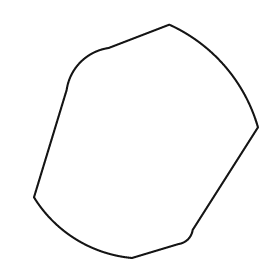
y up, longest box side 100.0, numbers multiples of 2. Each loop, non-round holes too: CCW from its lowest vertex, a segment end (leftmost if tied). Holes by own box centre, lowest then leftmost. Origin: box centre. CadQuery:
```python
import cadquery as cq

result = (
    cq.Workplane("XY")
    .moveTo(-6.0, -50.0)
    .lineTo(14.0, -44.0)
    .threePointArc((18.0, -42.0), (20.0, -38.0))
    .lineTo(48.0, 6.0)
    .threePointArc((34.0, 32.0), (10.0, 50.0))
    .lineTo(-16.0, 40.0)
    .threePointArc((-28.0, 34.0), (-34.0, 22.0))
    .lineTo(-48.0, -24.0)
    .threePointArc((-30.0, -42.0), (-6.0, -50.0))
    .close()
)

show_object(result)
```